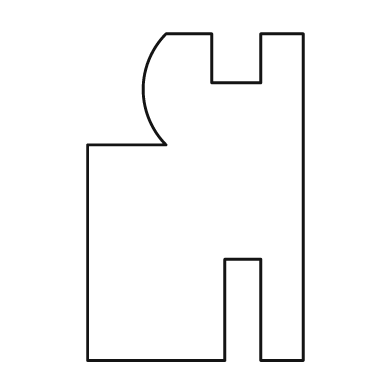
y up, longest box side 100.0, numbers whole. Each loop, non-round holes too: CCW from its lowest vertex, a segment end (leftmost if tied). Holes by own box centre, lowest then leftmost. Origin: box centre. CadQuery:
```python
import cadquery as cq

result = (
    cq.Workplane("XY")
    .moveTo(-33.0, -50.0)
    .lineTo(9.0, -50.0)
    .lineTo(9.0, -19.0)
    .lineTo(20.0, -19.0)
    .lineTo(20.0, -50.0)
    .lineTo(33.0, -50.0)
    .lineTo(33.0, 50.0)
    .lineTo(20.0, 50.0)
    .lineTo(20.0, 35.0)
    .lineTo(5.0, 35.0)
    .lineTo(5.0, 50.0)
    .lineTo(-9.0, 50.0)
    .threePointArc((-16.0, 33.0), (-9.0, 16.0))
    .lineTo(-33.0, 16.0)
    .close()
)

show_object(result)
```